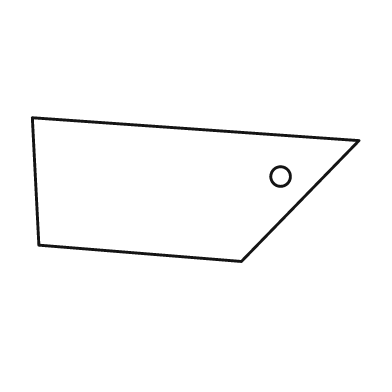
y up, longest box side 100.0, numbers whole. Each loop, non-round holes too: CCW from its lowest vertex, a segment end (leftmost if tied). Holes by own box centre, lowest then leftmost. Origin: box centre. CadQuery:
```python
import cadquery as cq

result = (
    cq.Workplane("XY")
    .moveTo(14.0, -22.0)
    .lineTo(50.0, 15.0)
    .lineTo(-50.0, 22.0)
    .lineTo(-48.0, -17.0)
    .close()
    .moveTo(26.0, 4.0)
    .circle(3.0)
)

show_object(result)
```